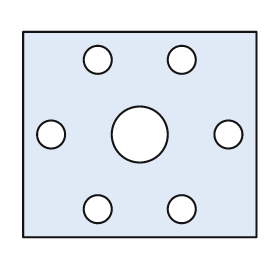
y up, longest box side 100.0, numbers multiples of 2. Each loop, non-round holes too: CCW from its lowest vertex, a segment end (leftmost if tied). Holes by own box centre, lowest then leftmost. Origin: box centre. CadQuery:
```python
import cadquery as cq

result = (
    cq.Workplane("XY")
    .moveTo(-50.0, -44.0)
    .lineTo(50.0, -44.0)
    .lineTo(50.0, 44.0)
    .lineTo(-50.0, 44.0)
    .close()
    .moveTo(-18.0, -32.0)
    .circle(6.0)
    .moveTo(18.0, -32.0)
    .circle(6.0)
    .moveTo(-38.0, 0.0)
    .circle(6.0)
    .moveTo(0.0, 0.0)
    .circle(12.0)
    .moveTo(38.0, 0.0)
    .circle(6.0)
    .moveTo(-18.0, 32.0)
    .circle(6.0)
    .moveTo(18.0, 32.0)
    .circle(6.0)
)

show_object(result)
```